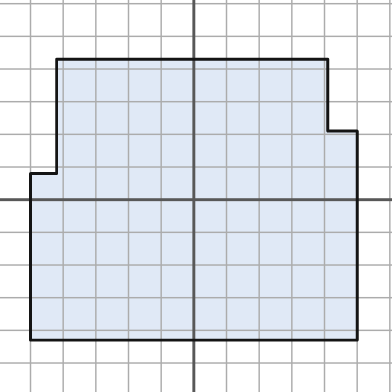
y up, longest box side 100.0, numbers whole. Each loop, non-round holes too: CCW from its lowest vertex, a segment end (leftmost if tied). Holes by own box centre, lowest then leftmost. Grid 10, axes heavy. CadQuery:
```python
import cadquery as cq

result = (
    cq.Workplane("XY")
    .moveTo(-50.0, -43.0)
    .lineTo(50.0, -43.0)
    .lineTo(50.0, 21.0)
    .lineTo(41.0, 21.0)
    .lineTo(41.0, 43.0)
    .lineTo(-42.0, 43.0)
    .lineTo(-42.0, 8.0)
    .lineTo(-50.0, 8.0)
    .close()
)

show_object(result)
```